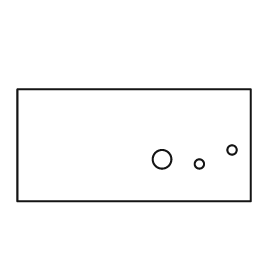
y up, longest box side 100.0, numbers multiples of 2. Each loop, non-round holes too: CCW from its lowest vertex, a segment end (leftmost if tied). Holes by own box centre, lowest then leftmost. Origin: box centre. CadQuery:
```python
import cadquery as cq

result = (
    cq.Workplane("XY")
    .moveTo(-50.0, -24.0)
    .lineTo(50.0, -24.0)
    .lineTo(50.0, 24.0)
    .lineTo(-50.0, 24.0)
    .close()
    .moveTo(28.0, -8.0)
    .circle(2.0)
    .moveTo(12.0, -6.0)
    .circle(4.0)
    .moveTo(42.0, -2.0)
    .circle(2.0)
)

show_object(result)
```